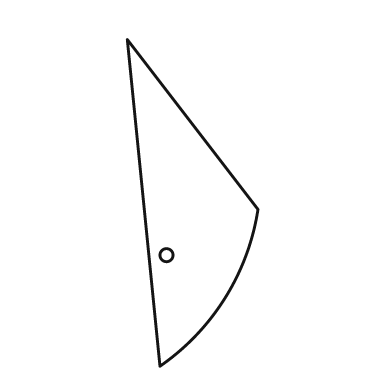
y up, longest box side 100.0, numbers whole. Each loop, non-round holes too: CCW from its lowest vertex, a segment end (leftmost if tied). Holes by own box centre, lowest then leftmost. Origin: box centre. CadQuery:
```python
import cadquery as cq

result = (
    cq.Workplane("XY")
    .moveTo(-10.0, -50.0)
    .threePointArc((10.0, -29.0), (20.0, -2.0))
    .lineTo(-20.0, 50.0)
    .close()
    .moveTo(-8.0, -16.0)
    .circle(2.0)
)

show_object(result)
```